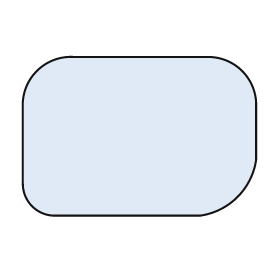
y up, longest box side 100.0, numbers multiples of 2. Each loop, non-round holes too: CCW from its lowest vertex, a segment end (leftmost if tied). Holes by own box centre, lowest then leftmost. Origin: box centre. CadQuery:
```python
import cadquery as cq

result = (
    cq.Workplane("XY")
    .moveTo(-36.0, -34.0)
    .lineTo(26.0, -34.0)
    .threePointArc((42.0, -26.0), (50.0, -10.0))
    .lineTo(50.0, 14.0)
    .threePointArc((44.0, 28.0), (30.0, 34.0))
    .lineTo(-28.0, 34.0)
    .threePointArc((-44.0, 28.0), (-50.0, 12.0))
    .lineTo(-50.0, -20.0)
    .threePointArc((-46.0, -30.0), (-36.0, -34.0))
    .close()
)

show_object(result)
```